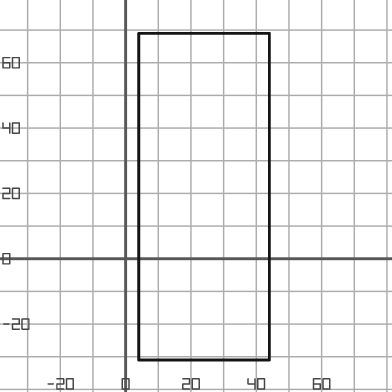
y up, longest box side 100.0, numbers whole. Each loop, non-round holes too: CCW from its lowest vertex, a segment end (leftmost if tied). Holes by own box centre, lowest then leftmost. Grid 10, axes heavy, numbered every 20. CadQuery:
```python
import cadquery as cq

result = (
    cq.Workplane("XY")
    .moveTo(4.0, -31.0)
    .lineTo(44.0, -31.0)
    .lineTo(44.0, 69.0)
    .lineTo(4.0, 69.0)
    .close()
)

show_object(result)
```